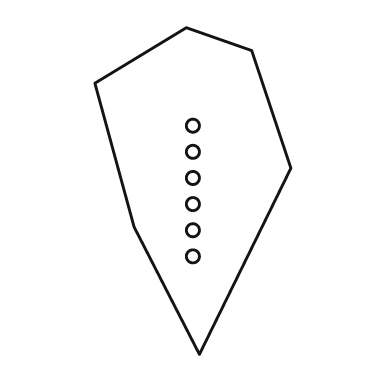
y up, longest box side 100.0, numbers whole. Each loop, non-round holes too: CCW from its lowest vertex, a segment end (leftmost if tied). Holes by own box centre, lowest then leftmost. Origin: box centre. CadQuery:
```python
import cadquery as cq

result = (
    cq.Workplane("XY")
    .moveTo(2.0, -50.0)
    .lineTo(30.0, 7.0)
    .lineTo(18.0, 43.0)
    .lineTo(-2.0, 50.0)
    .lineTo(-30.0, 33.0)
    .lineTo(-18.0, -11.0)
    .close()
    .moveTo(0.0, -20.0)
    .circle(2.0)
    .moveTo(0.0, -12.0)
    .circle(2.0)
    .moveTo(0.0, -4.0)
    .circle(2.0)
    .moveTo(0.0, 4.0)
    .circle(2.0)
    .moveTo(0.0, 12.0)
    .circle(2.0)
    .moveTo(0.0, 20.0)
    .circle(2.0)
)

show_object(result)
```